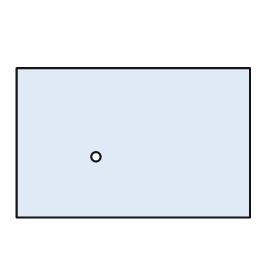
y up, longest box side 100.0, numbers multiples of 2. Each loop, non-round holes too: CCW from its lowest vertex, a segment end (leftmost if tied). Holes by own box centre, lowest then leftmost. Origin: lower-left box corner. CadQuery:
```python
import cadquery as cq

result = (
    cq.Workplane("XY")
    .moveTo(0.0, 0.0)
    .lineTo(100.0, 0.0)
    .lineTo(100.0, 64.0)
    .lineTo(0.0, 64.0)
    .close()
    .moveTo(34.0, 26.0)
    .circle(2.0)
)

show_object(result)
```